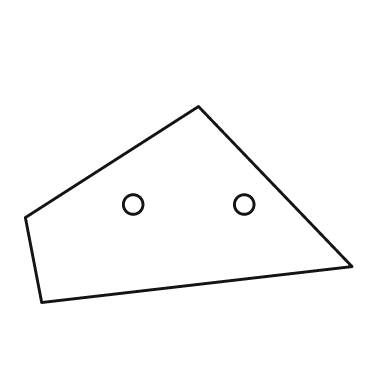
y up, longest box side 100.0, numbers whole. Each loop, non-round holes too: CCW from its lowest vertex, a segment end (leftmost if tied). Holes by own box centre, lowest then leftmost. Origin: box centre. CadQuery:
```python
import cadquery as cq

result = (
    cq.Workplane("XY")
    .moveTo(-45.0, -30.0)
    .lineTo(50.0, -19.0)
    .lineTo(3.0, 30.0)
    .lineTo(-50.0, -4.0)
    .close()
    .moveTo(-17.0, 0.0)
    .circle(3.0)
    .moveTo(17.0, 0.0)
    .circle(3.0)
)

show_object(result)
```